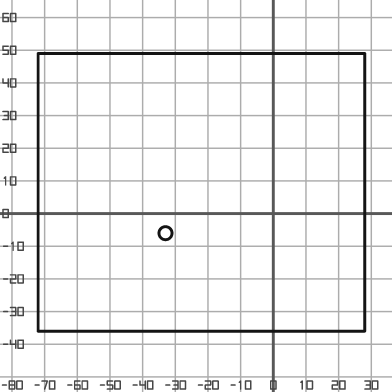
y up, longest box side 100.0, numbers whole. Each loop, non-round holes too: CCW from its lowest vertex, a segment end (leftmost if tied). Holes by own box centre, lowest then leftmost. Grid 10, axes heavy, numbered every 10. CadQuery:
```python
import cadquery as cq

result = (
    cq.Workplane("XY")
    .moveTo(-72.0, -36.0)
    .lineTo(28.0, -36.0)
    .lineTo(28.0, 49.0)
    .lineTo(-72.0, 49.0)
    .close()
    .moveTo(-33.0, -6.0)
    .circle(2.0)
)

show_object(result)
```